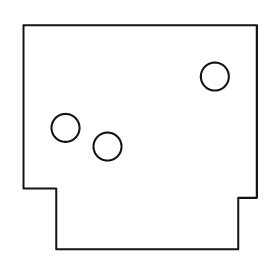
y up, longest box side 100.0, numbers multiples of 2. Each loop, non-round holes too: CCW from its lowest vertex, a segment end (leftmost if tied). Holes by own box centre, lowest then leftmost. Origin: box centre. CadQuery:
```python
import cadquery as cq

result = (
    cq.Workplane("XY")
    .moveTo(-36.0, -48.0)
    .lineTo(42.0, -48.0)
    .lineTo(42.0, -26.0)
    .lineTo(50.0, -26.0)
    .lineTo(50.0, 48.0)
    .lineTo(-50.0, 48.0)
    .lineTo(-50.0, -22.0)
    .lineTo(-36.0, -22.0)
    .close()
    .moveTo(-14.0, -4.0)
    .circle(6.0)
    .moveTo(-32.0, 4.0)
    .circle(6.0)
    .moveTo(32.0, 26.0)
    .circle(6.0)
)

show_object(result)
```